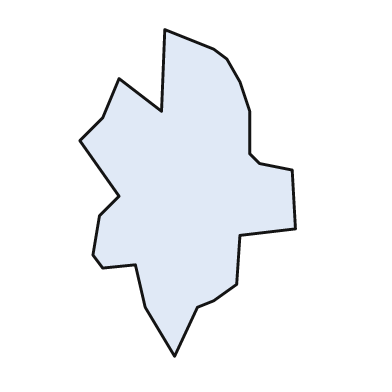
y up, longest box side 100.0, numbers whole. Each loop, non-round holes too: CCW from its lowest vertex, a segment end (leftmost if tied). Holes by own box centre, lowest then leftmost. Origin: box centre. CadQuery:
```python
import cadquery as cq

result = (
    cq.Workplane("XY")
    .moveTo(-4.0, -50.0)
    .lineTo(3.0, -35.0)
    .lineTo(8.0, -33.0)
    .lineTo(15.0, -28.0)
    .lineTo(16.0, -13.0)
    .lineTo(33.0, -11.0)
    .lineTo(32.0, 7.0)
    .lineTo(22.0, 9.0)
    .lineTo(19.0, 12.0)
    .lineTo(19.0, 25.0)
    .lineTo(16.0, 34.0)
    .lineTo(12.0, 41.0)
    .lineTo(8.0, 44.0)
    .lineTo(-7.0, 50.0)
    .lineTo(-8.0, 25.0)
    .lineTo(-21.0, 35.0)
    .lineTo(-26.0, 23.0)
    .lineTo(-33.0, 16.0)
    .lineTo(-21.0, -1.0)
    .lineTo(-27.0, -7.0)
    .lineTo(-29.0, -19.0)
    .lineTo(-26.0, -23.0)
    .lineTo(-16.0, -22.0)
    .lineTo(-13.0, -35.0)
    .close()
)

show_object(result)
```